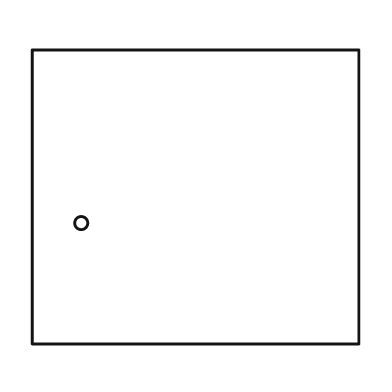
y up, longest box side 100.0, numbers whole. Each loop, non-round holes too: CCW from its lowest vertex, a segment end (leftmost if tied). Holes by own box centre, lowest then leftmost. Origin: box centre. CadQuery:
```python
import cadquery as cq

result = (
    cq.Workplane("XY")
    .moveTo(-50.0, -45.0)
    .lineTo(50.0, -45.0)
    .lineTo(50.0, 45.0)
    .lineTo(-50.0, 45.0)
    .close()
    .moveTo(-35.0, -8.0)
    .circle(2.0)
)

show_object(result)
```